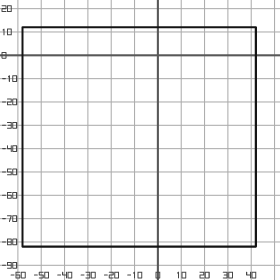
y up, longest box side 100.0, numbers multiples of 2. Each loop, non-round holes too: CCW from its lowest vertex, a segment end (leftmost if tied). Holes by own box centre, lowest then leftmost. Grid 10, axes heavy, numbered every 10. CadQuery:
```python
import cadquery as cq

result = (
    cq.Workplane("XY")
    .moveTo(-58.0, -82.0)
    .lineTo(42.0, -82.0)
    .lineTo(42.0, 12.0)
    .lineTo(-58.0, 12.0)
    .close()
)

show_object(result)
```